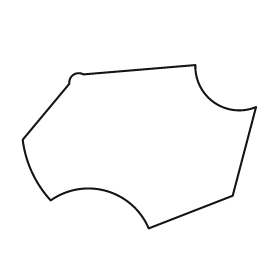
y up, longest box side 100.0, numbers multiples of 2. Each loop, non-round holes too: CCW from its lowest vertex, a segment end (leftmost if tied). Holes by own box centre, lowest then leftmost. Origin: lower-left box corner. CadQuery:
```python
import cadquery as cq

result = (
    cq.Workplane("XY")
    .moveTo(54.0, 0.0)
    .lineTo(90.0, 14.0)
    .lineTo(100.0, 52.0)
    .threePointArc((82.0, 54.0), (74.0, 70.0))
    .lineTo(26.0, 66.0)
    .threePointArc((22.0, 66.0), (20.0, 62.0))
    .lineTo(0.0, 38.0)
    .threePointArc((4.0, 24.0), (12.0, 12.0))
    .threePointArc((36.0, 16.0), (54.0, 0.0))
    .close()
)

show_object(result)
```